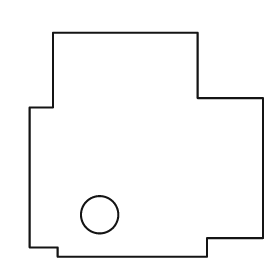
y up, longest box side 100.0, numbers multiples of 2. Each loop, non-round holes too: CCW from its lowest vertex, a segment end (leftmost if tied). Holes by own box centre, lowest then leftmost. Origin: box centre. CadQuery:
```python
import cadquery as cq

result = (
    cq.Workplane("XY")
    .moveTo(-38.0, -48.0)
    .lineTo(26.0, -48.0)
    .lineTo(26.0, -40.0)
    .lineTo(50.0, -40.0)
    .lineTo(50.0, 20.0)
    .lineTo(22.0, 20.0)
    .lineTo(22.0, 48.0)
    .lineTo(-40.0, 48.0)
    .lineTo(-40.0, 16.0)
    .lineTo(-50.0, 16.0)
    .lineTo(-50.0, -44.0)
    .lineTo(-38.0, -44.0)
    .close()
    .moveTo(-20.0, -30.0)
    .circle(8.0)
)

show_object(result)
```